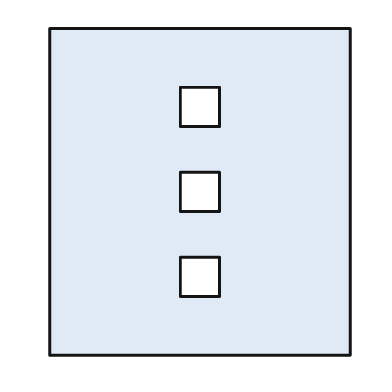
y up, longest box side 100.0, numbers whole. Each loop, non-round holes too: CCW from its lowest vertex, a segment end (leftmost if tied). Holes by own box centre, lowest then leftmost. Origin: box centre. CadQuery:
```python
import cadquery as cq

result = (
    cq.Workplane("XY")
    .moveTo(-46.0, -50.0)
    .lineTo(46.0, -50.0)
    .lineTo(46.0, 50.0)
    .lineTo(-46.0, 50.0)
    .close()
    .moveTo(-6.0, -32.0)
    .lineTo(6.0, -32.0)
    .lineTo(6.0, -20.0)
    .lineTo(-6.0, -20.0)
    .close()
    .moveTo(-6.0, -6.0)
    .lineTo(6.0, -6.0)
    .lineTo(6.0, 6.0)
    .lineTo(-6.0, 6.0)
    .close()
    .moveTo(-6.0, 20.0)
    .lineTo(6.0, 20.0)
    .lineTo(6.0, 32.0)
    .lineTo(-6.0, 32.0)
    .close()
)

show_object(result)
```